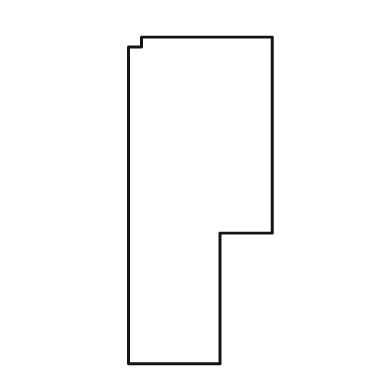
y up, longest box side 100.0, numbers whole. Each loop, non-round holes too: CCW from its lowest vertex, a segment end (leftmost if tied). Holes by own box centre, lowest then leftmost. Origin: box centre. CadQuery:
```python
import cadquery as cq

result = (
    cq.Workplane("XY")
    .moveTo(-22.0, -50.0)
    .lineTo(6.0, -50.0)
    .lineTo(6.0, -10.0)
    .lineTo(22.0, -10.0)
    .lineTo(22.0, 50.0)
    .lineTo(-18.0, 50.0)
    .lineTo(-18.0, 47.0)
    .lineTo(-22.0, 47.0)
    .close()
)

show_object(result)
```